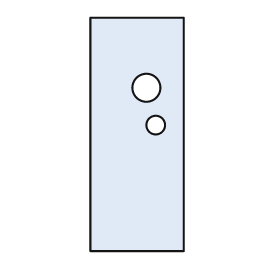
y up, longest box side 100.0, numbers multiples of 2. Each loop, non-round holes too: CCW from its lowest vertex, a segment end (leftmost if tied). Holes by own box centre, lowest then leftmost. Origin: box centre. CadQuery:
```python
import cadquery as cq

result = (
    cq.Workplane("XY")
    .moveTo(-20.0, -50.0)
    .lineTo(20.0, -50.0)
    .lineTo(20.0, 50.0)
    .lineTo(-20.0, 50.0)
    .close()
    .moveTo(8.0, 4.0)
    .circle(4.0)
    .moveTo(4.0, 20.0)
    .circle(6.0)
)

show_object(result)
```